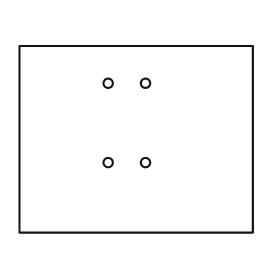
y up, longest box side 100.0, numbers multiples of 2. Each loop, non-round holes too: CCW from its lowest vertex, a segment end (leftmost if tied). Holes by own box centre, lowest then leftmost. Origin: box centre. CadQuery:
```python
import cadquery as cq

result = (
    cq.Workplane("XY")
    .moveTo(-50.0, -40.0)
    .lineTo(50.0, -40.0)
    .lineTo(50.0, 40.0)
    .lineTo(-50.0, 40.0)
    .close()
    .moveTo(-12.0, -10.0)
    .circle(2.0)
    .moveTo(4.0, -10.0)
    .circle(2.0)
    .moveTo(-12.0, 24.0)
    .circle(2.0)
    .moveTo(4.0, 24.0)
    .circle(2.0)
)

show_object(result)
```